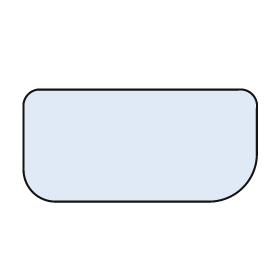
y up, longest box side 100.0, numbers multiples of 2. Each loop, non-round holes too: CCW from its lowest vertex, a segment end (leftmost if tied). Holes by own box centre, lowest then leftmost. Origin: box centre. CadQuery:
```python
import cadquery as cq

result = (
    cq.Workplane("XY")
    .moveTo(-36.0, -24.0)
    .lineTo(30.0, -24.0)
    .threePointArc((44.0, -18.0), (50.0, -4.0))
    .lineTo(50.0, 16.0)
    .threePointArc((48.0, 22.0), (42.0, 24.0))
    .lineTo(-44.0, 24.0)
    .threePointArc((-48.0, 22.0), (-50.0, 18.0))
    .lineTo(-50.0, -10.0)
    .threePointArc((-46.0, -20.0), (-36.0, -24.0))
    .close()
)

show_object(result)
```